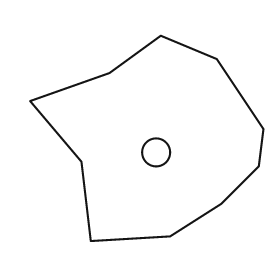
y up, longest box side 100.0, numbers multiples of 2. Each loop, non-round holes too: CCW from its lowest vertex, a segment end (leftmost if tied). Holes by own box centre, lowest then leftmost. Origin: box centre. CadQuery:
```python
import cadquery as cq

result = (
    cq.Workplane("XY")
    .moveTo(-24.0, -44.0)
    .lineTo(10.0, -42.0)
    .lineTo(32.0, -28.0)
    .lineTo(48.0, -12.0)
    .lineTo(50.0, 4.0)
    .lineTo(30.0, 34.0)
    .lineTo(6.0, 44.0)
    .lineTo(-16.0, 28.0)
    .lineTo(-50.0, 16.0)
    .lineTo(-28.0, -10.0)
    .close()
    .moveTo(4.0, -6.0)
    .circle(6.0)
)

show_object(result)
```